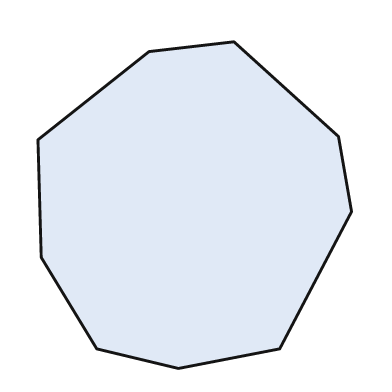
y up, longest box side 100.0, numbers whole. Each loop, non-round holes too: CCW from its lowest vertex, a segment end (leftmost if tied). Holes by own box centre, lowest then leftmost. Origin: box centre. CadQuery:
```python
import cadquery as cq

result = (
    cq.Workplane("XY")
    .moveTo(-5.0, -50.0)
    .lineTo(26.0, -44.0)
    .lineTo(48.0, -2.0)
    .lineTo(44.0, 21.0)
    .lineTo(12.0, 50.0)
    .lineTo(-14.0, 47.0)
    .lineTo(-48.0, 20.0)
    .lineTo(-47.0, -16.0)
    .lineTo(-30.0, -44.0)
    .close()
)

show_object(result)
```